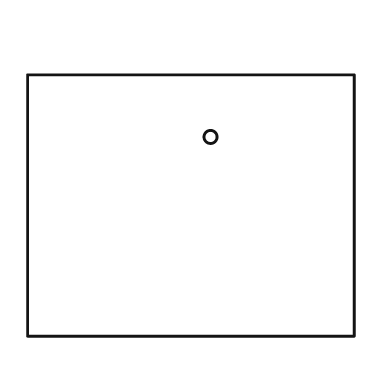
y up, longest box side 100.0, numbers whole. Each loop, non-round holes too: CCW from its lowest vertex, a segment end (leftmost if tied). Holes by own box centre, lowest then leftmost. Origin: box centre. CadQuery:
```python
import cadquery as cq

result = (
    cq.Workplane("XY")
    .moveTo(-50.0, -40.0)
    .lineTo(50.0, -40.0)
    .lineTo(50.0, 40.0)
    .lineTo(-50.0, 40.0)
    .close()
    .moveTo(6.0, 21.0)
    .circle(2.0)
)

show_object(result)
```